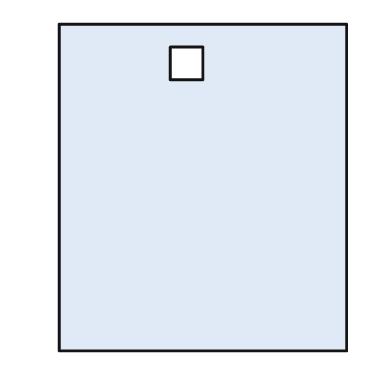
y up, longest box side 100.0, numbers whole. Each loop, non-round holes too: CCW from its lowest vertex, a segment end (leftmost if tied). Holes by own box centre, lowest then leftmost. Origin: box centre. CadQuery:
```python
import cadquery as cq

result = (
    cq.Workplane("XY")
    .moveTo(-44.0, -50.0)
    .lineTo(44.0, -50.0)
    .lineTo(44.0, 50.0)
    .lineTo(-44.0, 50.0)
    .close()
    .moveTo(-10.0, 33.0)
    .lineTo(0.0, 33.0)
    .lineTo(0.0, 43.0)
    .lineTo(-10.0, 43.0)
    .close()
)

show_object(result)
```